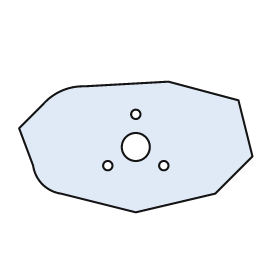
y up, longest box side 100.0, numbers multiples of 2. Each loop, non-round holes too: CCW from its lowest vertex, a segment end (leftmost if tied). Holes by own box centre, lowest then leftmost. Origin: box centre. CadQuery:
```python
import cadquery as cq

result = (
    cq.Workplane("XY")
    .moveTo(0.0, -28.0)
    .lineTo(34.0, -20.0)
    .lineTo(50.0, -4.0)
    .lineTo(44.0, 20.0)
    .lineTo(14.0, 28.0)
    .lineTo(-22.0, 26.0)
    .threePointArc((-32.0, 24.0), (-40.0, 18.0))
    .lineTo(-50.0, 8.0)
    .lineTo(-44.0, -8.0)
    .threePointArc((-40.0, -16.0), (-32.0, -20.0))
    .close()
    .moveTo(-12.0, -8.0)
    .circle(2.0)
    .moveTo(12.0, -8.0)
    .circle(2.0)
    .moveTo(0.0, 0.0)
    .circle(6.0)
    .moveTo(0.0, 14.0)
    .circle(2.0)
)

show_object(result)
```